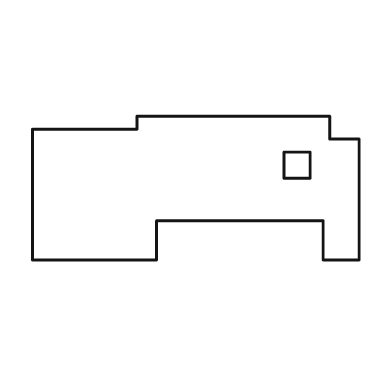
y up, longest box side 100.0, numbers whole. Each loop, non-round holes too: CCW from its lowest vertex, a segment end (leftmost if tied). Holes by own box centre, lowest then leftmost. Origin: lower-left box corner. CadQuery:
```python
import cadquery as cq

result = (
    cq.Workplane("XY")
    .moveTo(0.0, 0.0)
    .lineTo(38.0, 0.0)
    .lineTo(38.0, 12.0)
    .lineTo(89.0, 12.0)
    .lineTo(89.0, 0.0)
    .lineTo(100.0, 0.0)
    .lineTo(100.0, 37.0)
    .lineTo(91.0, 37.0)
    .lineTo(91.0, 44.0)
    .lineTo(32.0, 44.0)
    .lineTo(32.0, 40.0)
    .lineTo(0.0, 40.0)
    .close()
    .moveTo(77.0, 25.0)
    .lineTo(85.0, 25.0)
    .lineTo(85.0, 33.0)
    .lineTo(77.0, 33.0)
    .close()
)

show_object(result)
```